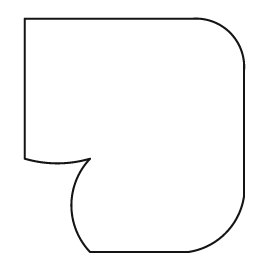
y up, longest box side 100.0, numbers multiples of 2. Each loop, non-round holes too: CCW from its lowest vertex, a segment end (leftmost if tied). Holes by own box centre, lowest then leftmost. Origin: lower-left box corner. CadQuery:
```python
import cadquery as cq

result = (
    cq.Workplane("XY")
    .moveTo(28.0, 0.0)
    .lineTo(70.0, 0.0)
    .threePointArc((86.0, 8.0), (94.0, 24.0))
    .lineTo(94.0, 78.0)
    .threePointArc((88.0, 94.0), (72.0, 100.0))
    .lineTo(0.0, 100.0)
    .lineTo(0.0, 40.0)
    .threePointArc((14.0, 38.0), (28.0, 40.0))
    .threePointArc((20.0, 20.0), (28.0, 0.0))
    .close()
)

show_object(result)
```